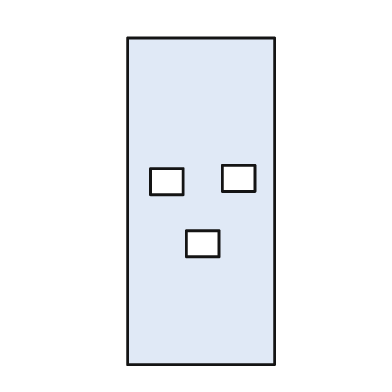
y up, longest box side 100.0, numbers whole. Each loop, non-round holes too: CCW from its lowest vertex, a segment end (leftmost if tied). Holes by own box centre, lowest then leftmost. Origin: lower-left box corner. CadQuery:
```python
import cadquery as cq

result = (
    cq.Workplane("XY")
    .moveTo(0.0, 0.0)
    .lineTo(45.0, 0.0)
    .lineTo(45.0, 100.0)
    .lineTo(0.0, 100.0)
    .close()
    .moveTo(18.0, 33.0)
    .lineTo(28.0, 33.0)
    .lineTo(28.0, 41.0)
    .lineTo(18.0, 41.0)
    .close()
    .moveTo(7.0, 52.0)
    .lineTo(17.0, 52.0)
    .lineTo(17.0, 60.0)
    .lineTo(7.0, 60.0)
    .close()
    .moveTo(29.0, 53.0)
    .lineTo(39.0, 53.0)
    .lineTo(39.0, 61.0)
    .lineTo(29.0, 61.0)
    .close()
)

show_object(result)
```